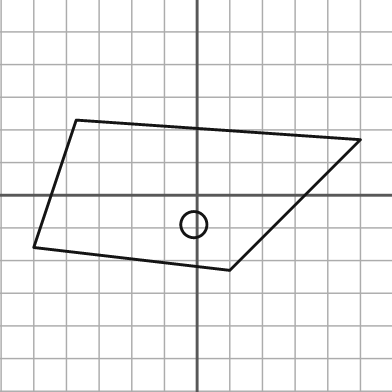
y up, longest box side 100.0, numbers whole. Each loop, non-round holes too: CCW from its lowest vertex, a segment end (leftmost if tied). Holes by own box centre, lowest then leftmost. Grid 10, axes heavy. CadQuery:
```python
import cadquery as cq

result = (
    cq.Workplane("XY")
    .moveTo(10.0, -23.0)
    .lineTo(50.0, 17.0)
    .lineTo(-37.0, 23.0)
    .lineTo(-50.0, -16.0)
    .close()
    .moveTo(-1.0, -9.0)
    .circle(4.0)
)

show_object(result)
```